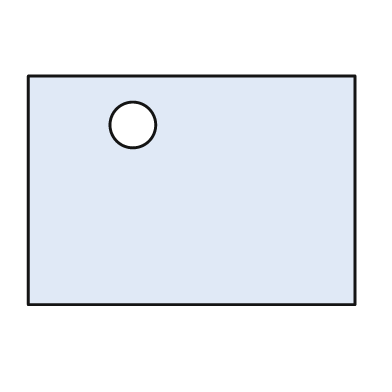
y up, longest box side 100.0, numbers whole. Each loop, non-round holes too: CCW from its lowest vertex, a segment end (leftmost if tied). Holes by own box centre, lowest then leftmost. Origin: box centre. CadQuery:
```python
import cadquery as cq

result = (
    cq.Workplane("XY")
    .moveTo(-50.0, -35.0)
    .lineTo(50.0, -35.0)
    .lineTo(50.0, 35.0)
    .lineTo(-50.0, 35.0)
    .close()
    .moveTo(-18.0, 20.0)
    .circle(7.0)
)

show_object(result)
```